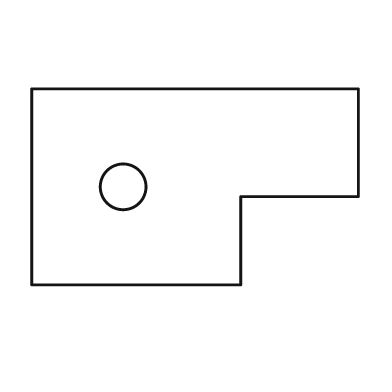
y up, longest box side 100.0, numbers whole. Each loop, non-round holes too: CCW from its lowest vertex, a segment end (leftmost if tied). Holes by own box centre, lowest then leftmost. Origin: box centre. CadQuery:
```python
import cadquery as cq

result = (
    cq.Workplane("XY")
    .moveTo(-50.0, -30.0)
    .lineTo(14.0, -30.0)
    .lineTo(14.0, -3.0)
    .lineTo(50.0, -3.0)
    .lineTo(50.0, 30.0)
    .lineTo(-50.0, 30.0)
    .close()
    .moveTo(-22.0, 0.0)
    .circle(7.0)
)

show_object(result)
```